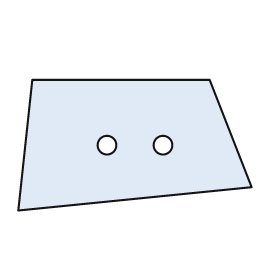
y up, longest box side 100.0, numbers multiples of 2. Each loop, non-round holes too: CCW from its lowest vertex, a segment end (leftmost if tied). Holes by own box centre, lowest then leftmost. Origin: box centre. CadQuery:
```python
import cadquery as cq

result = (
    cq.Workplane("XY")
    .moveTo(-50.0, -28.0)
    .lineTo(50.0, -18.0)
    .lineTo(32.0, 28.0)
    .lineTo(-44.0, 28.0)
    .close()
    .moveTo(-12.0, 0.0)
    .circle(4.0)
    .moveTo(12.0, 0.0)
    .circle(4.0)
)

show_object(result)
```